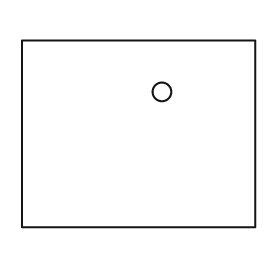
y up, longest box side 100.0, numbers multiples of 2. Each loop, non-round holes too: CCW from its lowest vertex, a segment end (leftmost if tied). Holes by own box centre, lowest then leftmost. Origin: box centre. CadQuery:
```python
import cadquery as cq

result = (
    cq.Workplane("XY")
    .moveTo(-50.0, -40.0)
    .lineTo(50.0, -40.0)
    .lineTo(50.0, 40.0)
    .lineTo(-50.0, 40.0)
    .close()
    .moveTo(10.0, 18.0)
    .circle(4.0)
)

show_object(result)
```